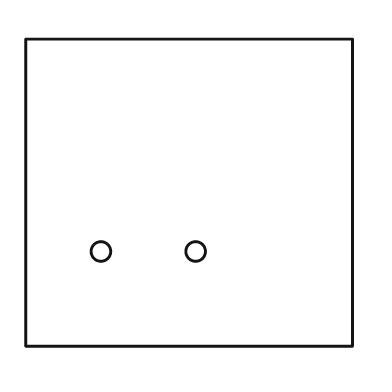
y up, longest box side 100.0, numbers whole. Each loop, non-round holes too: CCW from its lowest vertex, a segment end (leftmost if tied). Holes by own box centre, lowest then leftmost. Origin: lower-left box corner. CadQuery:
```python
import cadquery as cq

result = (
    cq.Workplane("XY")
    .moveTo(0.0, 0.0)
    .lineTo(100.0, 0.0)
    .lineTo(100.0, 94.0)
    .lineTo(0.0, 94.0)
    .close()
    .moveTo(23.0, 29.0)
    .circle(3.0)
    .moveTo(52.0, 29.0)
    .circle(3.0)
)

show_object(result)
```